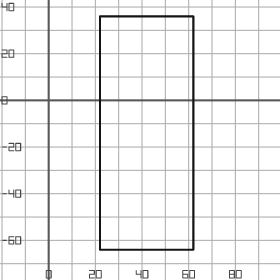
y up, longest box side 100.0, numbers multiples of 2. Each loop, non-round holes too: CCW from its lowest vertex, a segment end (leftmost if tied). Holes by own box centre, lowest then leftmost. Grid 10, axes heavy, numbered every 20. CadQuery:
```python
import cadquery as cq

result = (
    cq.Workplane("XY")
    .moveTo(22.0, -64.0)
    .lineTo(62.0, -64.0)
    .lineTo(62.0, 36.0)
    .lineTo(22.0, 36.0)
    .close()
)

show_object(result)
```